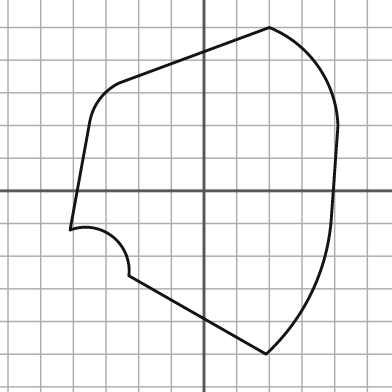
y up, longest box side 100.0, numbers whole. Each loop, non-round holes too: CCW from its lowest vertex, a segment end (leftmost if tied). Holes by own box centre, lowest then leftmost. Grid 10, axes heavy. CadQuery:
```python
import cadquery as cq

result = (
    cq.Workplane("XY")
    .moveTo(19.0, -50.0)
    .threePointArc((33.0, -31.0), (39.0, -8.0))
    .lineTo(41.0, 20.0)
    .threePointArc((35.0, 38.0), (20.0, 50.0))
    .lineTo(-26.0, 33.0)
    .threePointArc((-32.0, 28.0), (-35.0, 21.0))
    .lineTo(-41.0, -12.0)
    .threePointArc((-28.0, -14.0), (-23.0, -26.0))
    .close()
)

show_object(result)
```